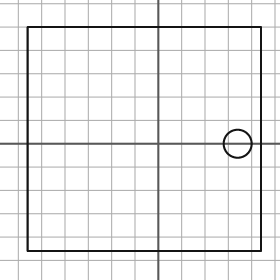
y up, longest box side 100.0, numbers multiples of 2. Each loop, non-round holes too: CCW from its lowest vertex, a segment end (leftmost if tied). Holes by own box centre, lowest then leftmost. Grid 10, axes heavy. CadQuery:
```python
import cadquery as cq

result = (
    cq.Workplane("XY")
    .moveTo(-56.0, -46.0)
    .lineTo(44.0, -46.0)
    .lineTo(44.0, 50.0)
    .lineTo(-56.0, 50.0)
    .close()
    .moveTo(34.0, 0.0)
    .circle(6.0)
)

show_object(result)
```